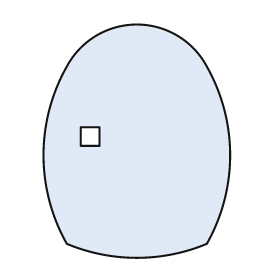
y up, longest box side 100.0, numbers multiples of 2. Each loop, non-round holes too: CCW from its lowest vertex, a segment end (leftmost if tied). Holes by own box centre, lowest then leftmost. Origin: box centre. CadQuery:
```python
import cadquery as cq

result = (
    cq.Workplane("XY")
    .moveTo(-30.0, -44.0)
    .threePointArc((0.0, -50.0), (30.0, -44.0))
    .threePointArc((40.0, -6.0), (30.0, 32.0))
    .threePointArc((0.0, 50.0), (-30.0, 32.0))
    .threePointArc((-40.0, -6.0), (-30.0, -44.0))
    .close()
    .moveTo(-24.0, -2.0)
    .lineTo(-16.0, -2.0)
    .lineTo(-16.0, 6.0)
    .lineTo(-24.0, 6.0)
    .close()
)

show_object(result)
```